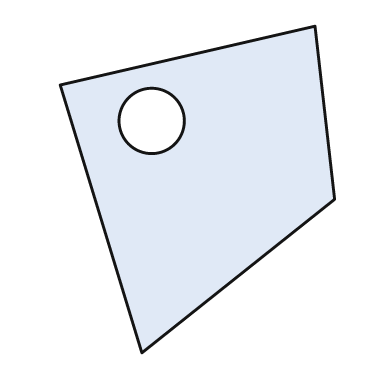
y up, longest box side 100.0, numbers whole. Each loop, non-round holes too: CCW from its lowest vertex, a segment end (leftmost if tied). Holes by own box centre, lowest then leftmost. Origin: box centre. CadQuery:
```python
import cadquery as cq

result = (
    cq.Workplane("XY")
    .moveTo(-17.0, -50.0)
    .lineTo(42.0, -3.0)
    .lineTo(36.0, 50.0)
    .lineTo(-42.0, 32.0)
    .close()
    .moveTo(-14.0, 21.0)
    .circle(10.0)
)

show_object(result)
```